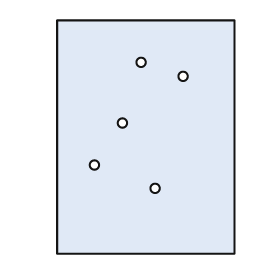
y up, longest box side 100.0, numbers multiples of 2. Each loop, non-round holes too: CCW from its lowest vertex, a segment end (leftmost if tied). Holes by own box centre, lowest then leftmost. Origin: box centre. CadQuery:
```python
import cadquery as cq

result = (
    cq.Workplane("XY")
    .moveTo(-38.0, -50.0)
    .lineTo(38.0, -50.0)
    .lineTo(38.0, 50.0)
    .lineTo(-38.0, 50.0)
    .close()
    .moveTo(4.0, -22.0)
    .circle(2.0)
    .moveTo(-22.0, -12.0)
    .circle(2.0)
    .moveTo(-10.0, 6.0)
    .circle(2.0)
    .moveTo(16.0, 26.0)
    .circle(2.0)
    .moveTo(-2.0, 32.0)
    .circle(2.0)
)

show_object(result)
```